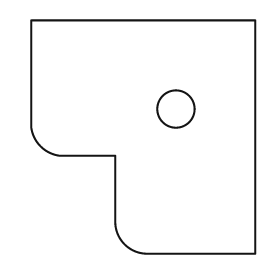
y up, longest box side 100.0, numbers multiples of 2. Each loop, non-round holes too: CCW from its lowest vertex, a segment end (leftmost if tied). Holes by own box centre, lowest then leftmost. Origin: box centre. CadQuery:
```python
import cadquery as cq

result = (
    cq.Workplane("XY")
    .moveTo(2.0, -50.0)
    .lineTo(48.0, -50.0)
    .lineTo(48.0, 50.0)
    .lineTo(-48.0, 50.0)
    .lineTo(-48.0, 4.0)
    .threePointArc((-44.0, -4.0), (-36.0, -8.0))
    .lineTo(-12.0, -8.0)
    .lineTo(-12.0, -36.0)
    .threePointArc((-8.0, -46.0), (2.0, -50.0))
    .close()
    .moveTo(14.0, 12.0)
    .circle(8.0)
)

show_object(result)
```